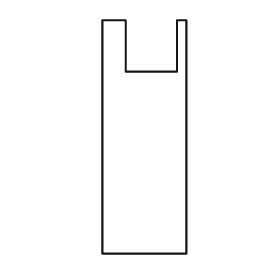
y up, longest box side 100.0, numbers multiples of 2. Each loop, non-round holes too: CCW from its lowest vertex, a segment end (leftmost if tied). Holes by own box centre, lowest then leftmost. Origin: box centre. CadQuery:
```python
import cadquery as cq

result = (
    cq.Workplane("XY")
    .moveTo(-18.0, -50.0)
    .lineTo(18.0, -50.0)
    .lineTo(18.0, 50.0)
    .lineTo(14.0, 50.0)
    .lineTo(14.0, 28.0)
    .lineTo(-8.0, 28.0)
    .lineTo(-8.0, 50.0)
    .lineTo(-18.0, 50.0)
    .close()
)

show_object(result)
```